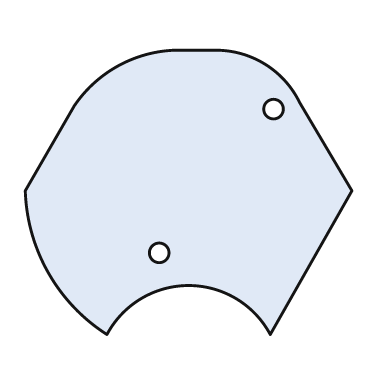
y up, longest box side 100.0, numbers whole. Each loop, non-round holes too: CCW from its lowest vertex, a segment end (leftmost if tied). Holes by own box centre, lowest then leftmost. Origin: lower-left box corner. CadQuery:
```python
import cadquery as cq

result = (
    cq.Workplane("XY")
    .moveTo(25.0, 0.0)
    .threePointArc((50.0, 15.0), (75.0, 0.0))
    .lineTo(100.0, 44.0)
    .lineTo(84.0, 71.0)
    .threePointArc((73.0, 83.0), (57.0, 87.0))
    .lineTo(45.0, 87.0)
    .threePointArc((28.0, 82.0), (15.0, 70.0))
    .lineTo(0.0, 44.0)
    .threePointArc((7.0, 19.0), (25.0, 0.0))
    .close()
    .moveTo(41.0, 25.0)
    .circle(3.0)
    .moveTo(76.0, 69.0)
    .circle(3.0)
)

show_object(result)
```